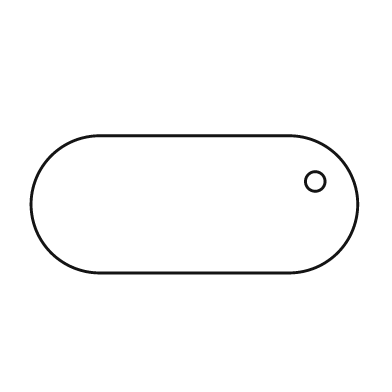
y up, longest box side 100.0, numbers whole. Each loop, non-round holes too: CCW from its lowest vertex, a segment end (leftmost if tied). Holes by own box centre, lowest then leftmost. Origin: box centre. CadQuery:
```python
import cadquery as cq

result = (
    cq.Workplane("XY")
    .moveTo(-29.0, -21.0)
    .lineTo(29.0, -21.0)
    .threePointArc((50.0, 0.0), (29.0, 21.0))
    .lineTo(-29.0, 21.0)
    .threePointArc((-50.0, 0.0), (-29.0, -21.0))
    .close()
    .moveTo(37.0, 7.0)
    .circle(3.0)
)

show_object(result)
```